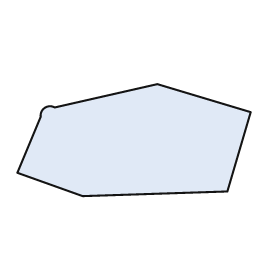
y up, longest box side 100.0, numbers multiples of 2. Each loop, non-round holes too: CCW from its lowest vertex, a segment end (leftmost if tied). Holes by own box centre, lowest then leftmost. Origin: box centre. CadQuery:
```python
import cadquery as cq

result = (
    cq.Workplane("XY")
    .moveTo(-22.0, -24.0)
    .lineTo(40.0, -22.0)
    .lineTo(50.0, 12.0)
    .lineTo(10.0, 24.0)
    .lineTo(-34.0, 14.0)
    .threePointArc((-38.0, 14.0), (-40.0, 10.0))
    .lineTo(-50.0, -14.0)
    .close()
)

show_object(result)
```